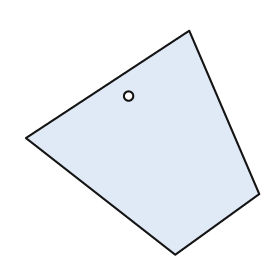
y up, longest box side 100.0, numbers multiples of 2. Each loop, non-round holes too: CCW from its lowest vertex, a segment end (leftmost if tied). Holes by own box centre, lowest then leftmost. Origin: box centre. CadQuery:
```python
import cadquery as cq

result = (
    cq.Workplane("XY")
    .moveTo(14.0, -48.0)
    .lineTo(50.0, -22.0)
    .lineTo(20.0, 48.0)
    .lineTo(-50.0, 2.0)
    .close()
    .moveTo(-6.0, 20.0)
    .circle(2.0)
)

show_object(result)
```